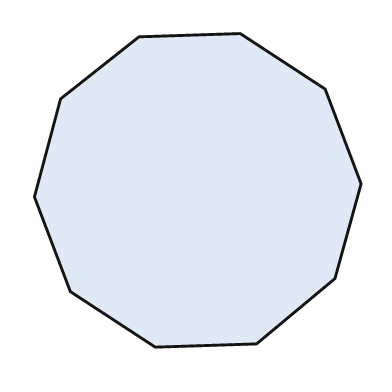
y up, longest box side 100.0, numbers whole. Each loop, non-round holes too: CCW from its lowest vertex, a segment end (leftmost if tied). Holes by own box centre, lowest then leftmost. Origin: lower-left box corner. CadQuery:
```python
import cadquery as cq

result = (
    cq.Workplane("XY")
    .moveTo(37.0, 0.0)
    .lineTo(68.0, 1.0)
    .lineTo(92.0, 21.0)
    .lineTo(100.0, 50.0)
    .lineTo(89.0, 79.0)
    .lineTo(63.0, 96.0)
    .lineTo(32.0, 95.0)
    .lineTo(8.0, 76.0)
    .lineTo(0.0, 46.0)
    .lineTo(11.0, 17.0)
    .close()
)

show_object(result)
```